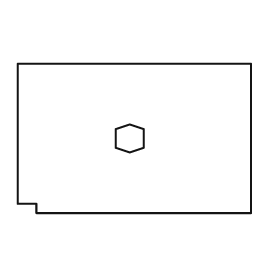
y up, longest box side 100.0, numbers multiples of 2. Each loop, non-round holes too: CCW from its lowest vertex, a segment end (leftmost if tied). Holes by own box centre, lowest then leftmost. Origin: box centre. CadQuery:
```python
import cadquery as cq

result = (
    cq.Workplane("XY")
    .moveTo(-42.0, -32.0)
    .lineTo(50.0, -32.0)
    .lineTo(50.0, 32.0)
    .lineTo(-50.0, 32.0)
    .lineTo(-50.0, -28.0)
    .lineTo(-42.0, -28.0)
    .close()
    .moveTo(-2.0, -6.0)
    .lineTo(4.0, -4.0)
    .lineTo(4.0, 4.0)
    .lineTo(-2.0, 6.0)
    .lineTo(-8.0, 4.0)
    .lineTo(-8.0, -4.0)
    .close()
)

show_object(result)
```